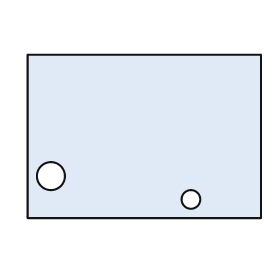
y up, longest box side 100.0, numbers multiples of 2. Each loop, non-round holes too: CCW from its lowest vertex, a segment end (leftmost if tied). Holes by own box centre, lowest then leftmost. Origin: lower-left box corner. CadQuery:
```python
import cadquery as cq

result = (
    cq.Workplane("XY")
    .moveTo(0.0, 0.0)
    .lineTo(100.0, 0.0)
    .lineTo(100.0, 70.0)
    .lineTo(0.0, 70.0)
    .close()
    .moveTo(70.0, 8.0)
    .circle(4.0)
    .moveTo(10.0, 18.0)
    .circle(6.0)
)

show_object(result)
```